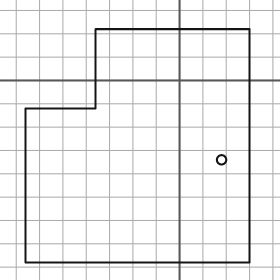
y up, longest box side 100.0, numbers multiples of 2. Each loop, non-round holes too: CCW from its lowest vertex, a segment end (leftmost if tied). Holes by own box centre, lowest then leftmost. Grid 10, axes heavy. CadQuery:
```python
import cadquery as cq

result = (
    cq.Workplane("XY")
    .moveTo(-66.0, -78.0)
    .lineTo(30.0, -78.0)
    .lineTo(30.0, 22.0)
    .lineTo(-36.0, 22.0)
    .lineTo(-36.0, -12.0)
    .lineTo(-66.0, -12.0)
    .close()
    .moveTo(18.0, -34.0)
    .circle(2.0)
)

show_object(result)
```